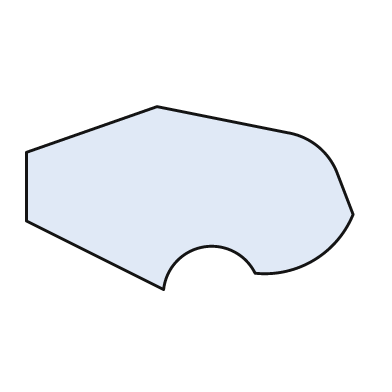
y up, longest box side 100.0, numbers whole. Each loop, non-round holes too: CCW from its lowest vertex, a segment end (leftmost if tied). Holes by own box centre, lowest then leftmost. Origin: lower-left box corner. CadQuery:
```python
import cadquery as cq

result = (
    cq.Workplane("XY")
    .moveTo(42.0, 0.0)
    .threePointArc((54.0, 13.0), (70.0, 5.0))
    .threePointArc((88.0, 9.0), (100.0, 23.0))
    .lineTo(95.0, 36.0)
    .threePointArc((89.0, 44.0), (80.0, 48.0))
    .lineTo(40.0, 56.0)
    .lineTo(0.0, 42.0)
    .lineTo(0.0, 21.0)
    .close()
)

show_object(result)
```